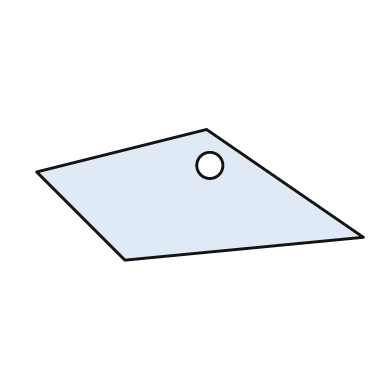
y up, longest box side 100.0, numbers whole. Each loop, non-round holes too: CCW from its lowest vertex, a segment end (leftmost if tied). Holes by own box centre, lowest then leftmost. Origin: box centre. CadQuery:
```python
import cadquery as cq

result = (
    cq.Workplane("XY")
    .moveTo(-23.0, -20.0)
    .lineTo(50.0, -13.0)
    .lineTo(2.0, 20.0)
    .lineTo(-50.0, 7.0)
    .close()
    .moveTo(3.0, 9.0)
    .circle(4.0)
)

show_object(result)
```